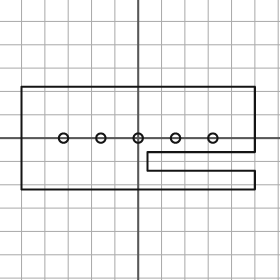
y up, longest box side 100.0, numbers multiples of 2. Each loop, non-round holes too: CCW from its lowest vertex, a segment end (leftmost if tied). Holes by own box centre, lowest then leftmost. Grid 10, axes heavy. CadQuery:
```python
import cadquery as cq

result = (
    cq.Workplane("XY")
    .moveTo(-50.0, -22.0)
    .lineTo(50.0, -22.0)
    .lineTo(50.0, -14.0)
    .lineTo(4.0, -14.0)
    .lineTo(4.0, -6.0)
    .lineTo(50.0, -6.0)
    .lineTo(50.0, 22.0)
    .lineTo(-50.0, 22.0)
    .close()
    .moveTo(-32.0, 0.0)
    .circle(2.0)
    .moveTo(-16.0, 0.0)
    .circle(2.0)
    .moveTo(0.0, 0.0)
    .circle(2.0)
    .moveTo(16.0, 0.0)
    .circle(2.0)
    .moveTo(32.0, 0.0)
    .circle(2.0)
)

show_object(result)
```